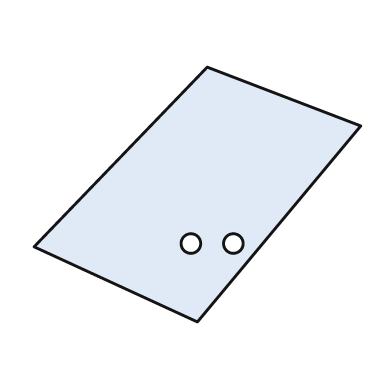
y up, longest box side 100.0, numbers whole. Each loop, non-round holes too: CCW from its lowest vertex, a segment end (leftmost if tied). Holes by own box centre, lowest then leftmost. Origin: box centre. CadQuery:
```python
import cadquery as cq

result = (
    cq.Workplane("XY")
    .moveTo(0.0, -39.0)
    .lineTo(50.0, 21.0)
    .lineTo(3.0, 39.0)
    .lineTo(-50.0, -16.0)
    .close()
    .moveTo(-2.0, -15.0)
    .circle(3.0)
    .moveTo(11.0, -15.0)
    .circle(3.0)
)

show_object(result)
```